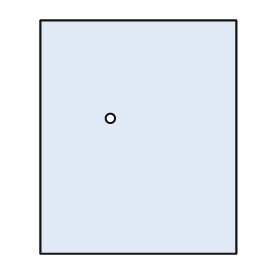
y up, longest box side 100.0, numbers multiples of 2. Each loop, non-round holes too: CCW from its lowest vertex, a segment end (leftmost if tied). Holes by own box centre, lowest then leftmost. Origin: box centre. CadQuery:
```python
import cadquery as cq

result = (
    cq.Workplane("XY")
    .moveTo(-42.0, -50.0)
    .lineTo(42.0, -50.0)
    .lineTo(42.0, 50.0)
    .lineTo(-42.0, 50.0)
    .close()
    .moveTo(-12.0, 8.0)
    .circle(2.0)
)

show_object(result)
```